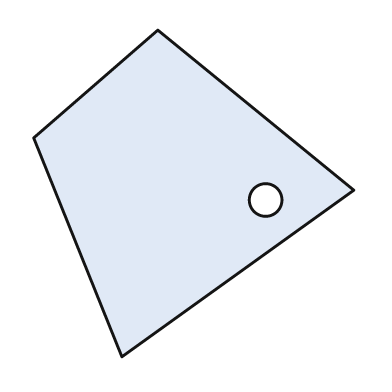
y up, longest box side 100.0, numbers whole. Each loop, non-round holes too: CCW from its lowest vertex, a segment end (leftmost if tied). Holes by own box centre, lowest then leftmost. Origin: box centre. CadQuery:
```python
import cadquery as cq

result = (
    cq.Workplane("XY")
    .moveTo(-22.0, -50.0)
    .lineTo(49.0, 1.0)
    .lineTo(-11.0, 50.0)
    .lineTo(-49.0, 17.0)
    .close()
    .moveTo(22.0, -2.0)
    .circle(5.0)
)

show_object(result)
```